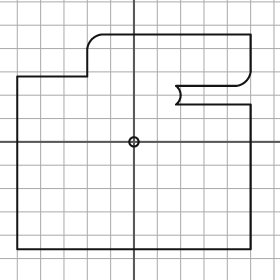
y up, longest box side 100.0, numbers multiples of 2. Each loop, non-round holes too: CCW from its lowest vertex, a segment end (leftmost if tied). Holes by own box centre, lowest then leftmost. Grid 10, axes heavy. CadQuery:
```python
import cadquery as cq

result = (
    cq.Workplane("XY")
    .moveTo(-50.0, -46.0)
    .lineTo(50.0, -46.0)
    .lineTo(50.0, 16.0)
    .lineTo(18.0, 16.0)
    .threePointArc((20.0, 20.0), (18.0, 24.0))
    .lineTo(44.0, 24.0)
    .threePointArc((48.0, 26.0), (50.0, 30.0))
    .lineTo(50.0, 46.0)
    .lineTo(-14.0, 46.0)
    .threePointArc((-18.0, 44.0), (-20.0, 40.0))
    .lineTo(-20.0, 28.0)
    .lineTo(-50.0, 28.0)
    .close()
    .moveTo(0.0, 0.0)
    .circle(2.0)
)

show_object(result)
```